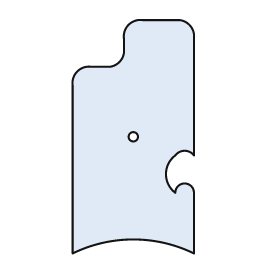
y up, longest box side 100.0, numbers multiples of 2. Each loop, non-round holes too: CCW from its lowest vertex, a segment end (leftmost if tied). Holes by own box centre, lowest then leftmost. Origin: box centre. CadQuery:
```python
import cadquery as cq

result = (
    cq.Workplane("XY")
    .moveTo(-26.0, -50.0)
    .threePointArc((0.0, -44.0), (26.0, -50.0))
    .lineTo(26.0, -24.0)
    .threePointArc((22.0, -20.0), (18.0, -24.0))
    .threePointArc((14.0, -16.0), (18.0, -8.0))
    .threePointArc((22.0, -6.0), (26.0, -8.0))
    .lineTo(26.0, 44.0)
    .threePointArc((24.0, 48.0), (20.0, 50.0))
    .lineTo(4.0, 50.0)
    .threePointArc((-2.0, 48.0), (-4.0, 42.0))
    .lineTo(-4.0, 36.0)
    .threePointArc((-6.0, 32.0), (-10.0, 30.0))
    .lineTo(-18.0, 30.0)
    .threePointArc((-24.0, 28.0), (-26.0, 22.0))
    .close()
    .moveTo(0.0, 0.0)
    .circle(2.0)
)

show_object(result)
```